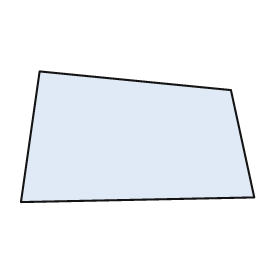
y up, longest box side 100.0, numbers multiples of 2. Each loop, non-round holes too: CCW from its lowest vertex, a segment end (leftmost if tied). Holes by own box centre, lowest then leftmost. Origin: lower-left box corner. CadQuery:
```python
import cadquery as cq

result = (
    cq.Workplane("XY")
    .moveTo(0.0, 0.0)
    .lineTo(100.0, 2.0)
    .lineTo(90.0, 48.0)
    .lineTo(8.0, 56.0)
    .close()
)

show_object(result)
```